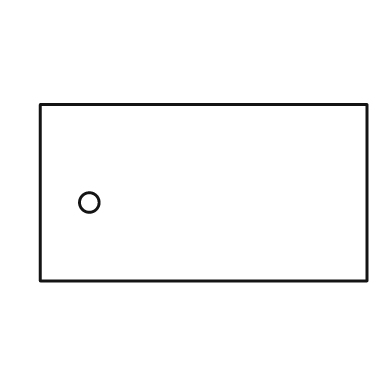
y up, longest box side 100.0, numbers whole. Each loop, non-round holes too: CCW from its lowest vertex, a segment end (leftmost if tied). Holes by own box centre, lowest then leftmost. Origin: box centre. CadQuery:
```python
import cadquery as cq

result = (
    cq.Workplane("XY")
    .moveTo(-50.0, -27.0)
    .lineTo(50.0, -27.0)
    .lineTo(50.0, 27.0)
    .lineTo(-50.0, 27.0)
    .close()
    .moveTo(-35.0, -3.0)
    .circle(3.0)
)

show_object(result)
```